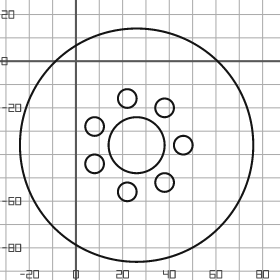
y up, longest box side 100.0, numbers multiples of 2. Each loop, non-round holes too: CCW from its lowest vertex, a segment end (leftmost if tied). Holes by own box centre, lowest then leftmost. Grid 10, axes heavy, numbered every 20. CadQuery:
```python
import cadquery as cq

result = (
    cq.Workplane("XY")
    .moveTo(26.0, -36.0)
    .circle(50.0)
    .moveTo(22.0, -56.0)
    .circle(4.0)
    .moveTo(38.0, -52.0)
    .circle(4.0)
    .moveTo(8.0, -44.0)
    .circle(4.0)
    .moveTo(26.0, -36.0)
    .circle(12.0)
    .moveTo(46.0, -36.0)
    .circle(4.0)
    .moveTo(8.0, -28.0)
    .circle(4.0)
    .moveTo(38.0, -20.0)
    .circle(4.0)
    .moveTo(22.0, -16.0)
    .circle(4.0)
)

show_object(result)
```